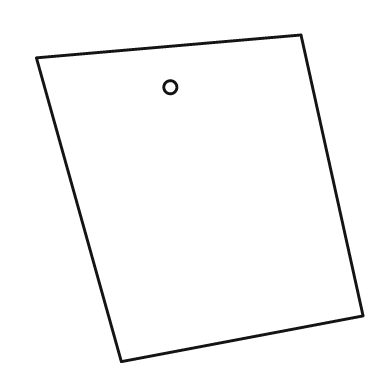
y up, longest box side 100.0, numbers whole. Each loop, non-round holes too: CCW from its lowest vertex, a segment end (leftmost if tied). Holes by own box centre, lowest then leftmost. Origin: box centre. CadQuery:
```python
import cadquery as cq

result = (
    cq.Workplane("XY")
    .moveTo(-24.0, -50.0)
    .lineTo(50.0, -36.0)
    .lineTo(31.0, 50.0)
    .lineTo(-50.0, 43.0)
    .close()
    .moveTo(-9.0, 34.0)
    .circle(2.0)
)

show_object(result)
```